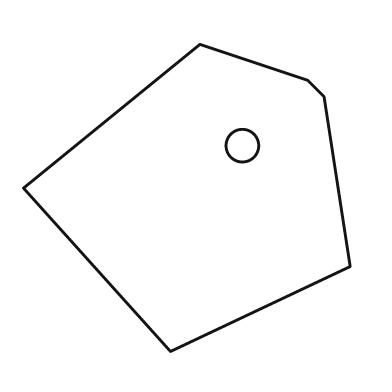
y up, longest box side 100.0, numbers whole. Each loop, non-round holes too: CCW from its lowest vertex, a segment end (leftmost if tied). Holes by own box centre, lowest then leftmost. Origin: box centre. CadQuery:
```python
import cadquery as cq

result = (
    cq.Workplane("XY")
    .moveTo(-5.0, -47.0)
    .lineTo(50.0, -21.0)
    .lineTo(42.0, 31.0)
    .lineTo(37.0, 36.0)
    .lineTo(4.0, 47.0)
    .lineTo(-50.0, 3.0)
    .close()
    .moveTo(17.0, 16.0)
    .circle(5.0)
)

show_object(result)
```